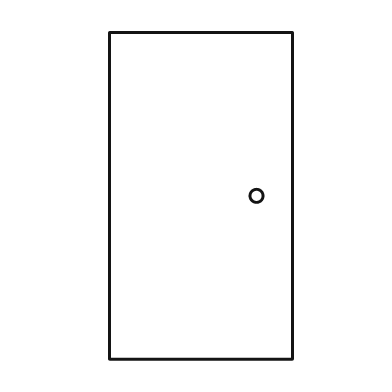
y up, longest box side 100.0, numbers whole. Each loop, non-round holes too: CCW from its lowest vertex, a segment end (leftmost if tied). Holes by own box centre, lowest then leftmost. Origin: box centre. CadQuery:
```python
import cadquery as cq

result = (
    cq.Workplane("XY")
    .moveTo(-28.0, -50.0)
    .lineTo(28.0, -50.0)
    .lineTo(28.0, 50.0)
    .lineTo(-28.0, 50.0)
    .close()
    .moveTo(17.0, 0.0)
    .circle(2.0)
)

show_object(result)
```